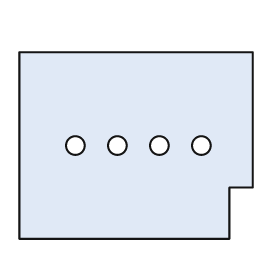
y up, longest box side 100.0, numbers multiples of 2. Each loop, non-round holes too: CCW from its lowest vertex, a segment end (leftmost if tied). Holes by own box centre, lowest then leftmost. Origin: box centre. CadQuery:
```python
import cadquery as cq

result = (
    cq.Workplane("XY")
    .moveTo(-50.0, -40.0)
    .lineTo(40.0, -40.0)
    .lineTo(40.0, -18.0)
    .lineTo(50.0, -18.0)
    .lineTo(50.0, 40.0)
    .lineTo(-50.0, 40.0)
    .close()
    .moveTo(-26.0, 0.0)
    .circle(4.0)
    .moveTo(-8.0, 0.0)
    .circle(4.0)
    .moveTo(10.0, 0.0)
    .circle(4.0)
    .moveTo(28.0, 0.0)
    .circle(4.0)
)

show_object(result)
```